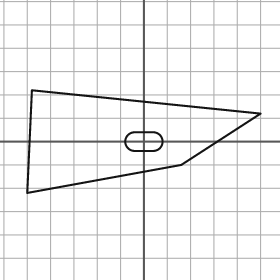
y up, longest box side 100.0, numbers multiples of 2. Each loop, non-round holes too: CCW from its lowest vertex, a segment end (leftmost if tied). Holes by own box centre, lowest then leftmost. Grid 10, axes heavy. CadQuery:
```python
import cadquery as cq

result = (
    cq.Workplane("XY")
    .moveTo(-50.0, -22.0)
    .lineTo(16.0, -10.0)
    .lineTo(50.0, 12.0)
    .lineTo(-48.0, 22.0)
    .close()
    .moveTo(-4.0, -4.0)
    .lineTo(4.0, -4.0)
    .threePointArc((8.0, 0.0), (4.0, 4.0))
    .lineTo(-4.0, 4.0)
    .threePointArc((-8.0, 0.0), (-4.0, -4.0))
    .close()
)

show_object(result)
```